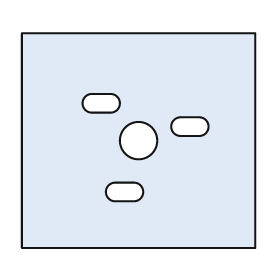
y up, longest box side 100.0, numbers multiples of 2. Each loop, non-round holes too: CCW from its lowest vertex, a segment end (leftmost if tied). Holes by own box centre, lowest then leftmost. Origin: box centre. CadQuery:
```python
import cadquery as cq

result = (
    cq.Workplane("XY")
    .moveTo(-50.0, -46.0)
    .lineTo(50.0, -46.0)
    .lineTo(50.0, 46.0)
    .lineTo(-50.0, 46.0)
    .close()
    .moveTo(-10.0, -26.0)
    .lineTo(-2.0, -26.0)
    .threePointArc((2.0, -22.0), (-2.0, -18.0))
    .lineTo(-10.0, -18.0)
    .threePointArc((-14.0, -22.0), (-10.0, -26.0))
    .close()
    .moveTo(0.0, 0.0)
    .circle(8.0)
    .moveTo(18.0, 2.0)
    .lineTo(26.0, 2.0)
    .threePointArc((30.0, 6.0), (26.0, 10.0))
    .lineTo(18.0, 10.0)
    .threePointArc((14.0, 6.0), (18.0, 2.0))
    .close()
    .moveTo(-20.0, 12.0)
    .lineTo(-12.0, 12.0)
    .threePointArc((-8.0, 16.0), (-12.0, 20.0))
    .lineTo(-20.0, 20.0)
    .threePointArc((-24.0, 16.0), (-20.0, 12.0))
    .close()
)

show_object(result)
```